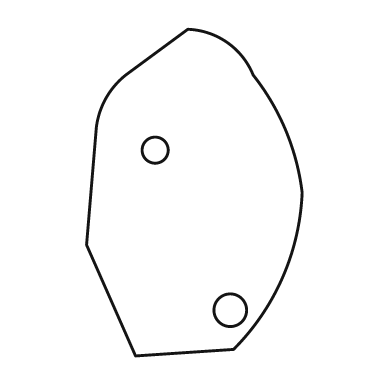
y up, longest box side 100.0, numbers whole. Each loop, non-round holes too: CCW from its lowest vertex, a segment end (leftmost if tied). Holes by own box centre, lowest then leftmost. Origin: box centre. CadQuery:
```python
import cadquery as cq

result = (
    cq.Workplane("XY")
    .moveTo(-18.0, -50.0)
    .lineTo(12.0, -48.0)
    .threePointArc((27.0, -26.0), (33.0, 0.0))
    .threePointArc((28.0, 19.0), (18.0, 36.0))
    .threePointArc((10.0, 46.0), (-2.0, 50.0))
    .lineTo(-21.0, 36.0)
    .threePointArc((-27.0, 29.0), (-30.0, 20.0))
    .lineTo(-33.0, -16.0)
    .close()
    .moveTo(11.0, -36.0)
    .circle(5.0)
    .moveTo(-12.0, 13.0)
    .circle(4.0)
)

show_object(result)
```